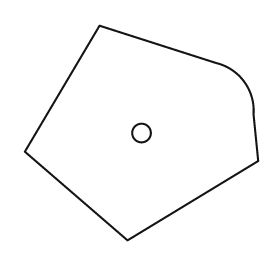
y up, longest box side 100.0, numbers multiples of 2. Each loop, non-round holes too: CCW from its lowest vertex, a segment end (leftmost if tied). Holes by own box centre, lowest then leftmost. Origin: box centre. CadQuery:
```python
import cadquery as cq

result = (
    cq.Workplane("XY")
    .moveTo(-6.0, -46.0)
    .lineTo(50.0, -12.0)
    .lineTo(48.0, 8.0)
    .threePointArc((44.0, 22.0), (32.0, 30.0))
    .lineTo(-18.0, 46.0)
    .lineTo(-50.0, -8.0)
    .close()
    .moveTo(0.0, 0.0)
    .circle(4.0)
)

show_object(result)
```